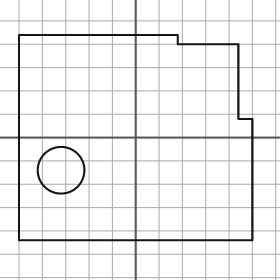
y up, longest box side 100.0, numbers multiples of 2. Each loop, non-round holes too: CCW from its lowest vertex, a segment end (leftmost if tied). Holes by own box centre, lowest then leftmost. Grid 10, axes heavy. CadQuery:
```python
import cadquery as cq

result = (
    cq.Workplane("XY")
    .moveTo(-50.0, -44.0)
    .lineTo(50.0, -44.0)
    .lineTo(50.0, 8.0)
    .lineTo(44.0, 8.0)
    .lineTo(44.0, 40.0)
    .lineTo(18.0, 40.0)
    .lineTo(18.0, 44.0)
    .lineTo(-50.0, 44.0)
    .close()
    .moveTo(-32.0, -14.0)
    .circle(10.0)
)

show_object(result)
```